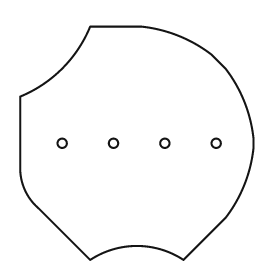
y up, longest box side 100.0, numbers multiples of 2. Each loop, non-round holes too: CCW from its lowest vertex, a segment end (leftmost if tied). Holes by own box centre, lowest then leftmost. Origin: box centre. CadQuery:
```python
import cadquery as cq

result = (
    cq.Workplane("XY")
    .moveTo(-20.0, -50.0)
    .threePointArc((0.0, -44.0), (20.0, -50.0))
    .lineTo(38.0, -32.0)
    .threePointArc((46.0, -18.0), (50.0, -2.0))
    .lineTo(50.0, 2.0)
    .threePointArc((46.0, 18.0), (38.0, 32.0))
    .lineTo(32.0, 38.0)
    .threePointArc((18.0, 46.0), (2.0, 50.0))
    .lineTo(-20.0, 50.0)
    .threePointArc((-32.0, 32.0), (-50.0, 20.0))
    .lineTo(-50.0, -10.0)
    .threePointArc((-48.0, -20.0), (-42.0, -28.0))
    .close()
    .moveTo(-32.0, 0.0)
    .circle(2.0)
    .moveTo(-10.0, 0.0)
    .circle(2.0)
    .moveTo(12.0, 0.0)
    .circle(2.0)
    .moveTo(34.0, 0.0)
    .circle(2.0)
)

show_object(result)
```